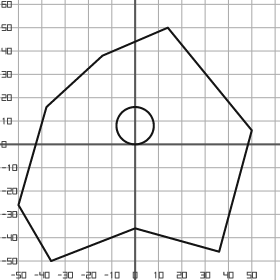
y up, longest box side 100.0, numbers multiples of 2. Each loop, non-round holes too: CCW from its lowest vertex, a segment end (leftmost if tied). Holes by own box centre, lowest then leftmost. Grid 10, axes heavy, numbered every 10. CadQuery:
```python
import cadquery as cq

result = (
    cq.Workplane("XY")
    .moveTo(-36.0, -50.0)
    .lineTo(0.0, -36.0)
    .lineTo(36.0, -46.0)
    .lineTo(50.0, 6.0)
    .lineTo(14.0, 50.0)
    .lineTo(-14.0, 38.0)
    .lineTo(-38.0, 16.0)
    .lineTo(-50.0, -26.0)
    .close()
    .moveTo(0.0, 8.0)
    .circle(8.0)
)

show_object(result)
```